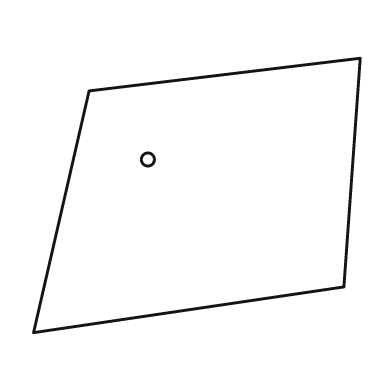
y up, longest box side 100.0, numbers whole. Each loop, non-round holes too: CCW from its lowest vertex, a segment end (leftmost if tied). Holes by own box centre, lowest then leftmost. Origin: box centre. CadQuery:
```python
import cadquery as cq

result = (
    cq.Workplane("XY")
    .moveTo(-50.0, -42.0)
    .lineTo(45.0, -28.0)
    .lineTo(50.0, 42.0)
    .lineTo(-33.0, 32.0)
    .close()
    .moveTo(-15.0, 11.0)
    .circle(2.0)
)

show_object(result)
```